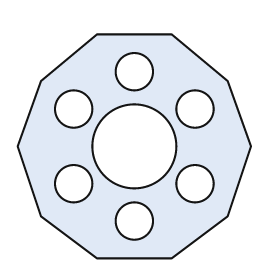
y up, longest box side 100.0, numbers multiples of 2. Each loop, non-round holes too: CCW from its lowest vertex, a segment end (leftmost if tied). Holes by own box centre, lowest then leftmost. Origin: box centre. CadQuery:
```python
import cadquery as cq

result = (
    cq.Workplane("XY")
    .moveTo(-16.0, -48.0)
    .lineTo(16.0, -48.0)
    .lineTo(40.0, -30.0)
    .lineTo(50.0, 0.0)
    .lineTo(40.0, 28.0)
    .lineTo(16.0, 48.0)
    .lineTo(-16.0, 48.0)
    .lineTo(-40.0, 28.0)
    .lineTo(-50.0, 0.0)
    .lineTo(-40.0, -30.0)
    .close()
    .moveTo(0.0, -32.0)
    .circle(8.0)
    .moveTo(-26.0, -16.0)
    .circle(8.0)
    .moveTo(26.0, -16.0)
    .circle(8.0)
    .moveTo(0.0, 0.0)
    .circle(18.0)
    .moveTo(-26.0, 16.0)
    .circle(8.0)
    .moveTo(26.0, 16.0)
    .circle(8.0)
    .moveTo(0.0, 32.0)
    .circle(8.0)
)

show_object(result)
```